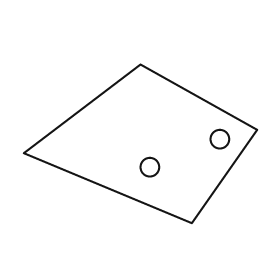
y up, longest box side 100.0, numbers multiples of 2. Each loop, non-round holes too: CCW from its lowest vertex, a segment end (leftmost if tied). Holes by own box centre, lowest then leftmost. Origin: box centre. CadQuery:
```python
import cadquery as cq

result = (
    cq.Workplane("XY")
    .moveTo(22.0, -34.0)
    .lineTo(50.0, 6.0)
    .lineTo(0.0, 34.0)
    .lineTo(-50.0, -4.0)
    .close()
    .moveTo(4.0, -10.0)
    .circle(4.0)
    .moveTo(34.0, 2.0)
    .circle(4.0)
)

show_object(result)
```